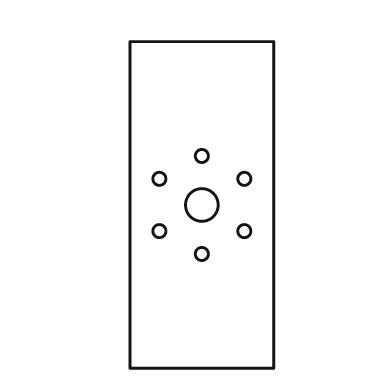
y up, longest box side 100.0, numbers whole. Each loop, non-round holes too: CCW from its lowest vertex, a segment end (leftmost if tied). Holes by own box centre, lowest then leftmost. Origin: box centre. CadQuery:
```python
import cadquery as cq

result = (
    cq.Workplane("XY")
    .moveTo(-22.0, -50.0)
    .lineTo(22.0, -50.0)
    .lineTo(22.0, 50.0)
    .lineTo(-22.0, 50.0)
    .close()
    .moveTo(0.0, -15.0)
    .circle(2.0)
    .moveTo(-13.0, -8.0)
    .circle(2.0)
    .moveTo(13.0, -8.0)
    .circle(2.0)
    .moveTo(0.0, 0.0)
    .circle(5.0)
    .moveTo(-13.0, 8.0)
    .circle(2.0)
    .moveTo(13.0, 8.0)
    .circle(2.0)
    .moveTo(0.0, 15.0)
    .circle(2.0)
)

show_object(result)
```